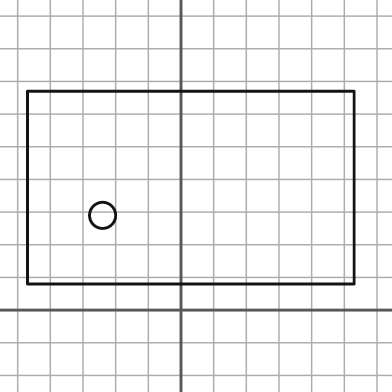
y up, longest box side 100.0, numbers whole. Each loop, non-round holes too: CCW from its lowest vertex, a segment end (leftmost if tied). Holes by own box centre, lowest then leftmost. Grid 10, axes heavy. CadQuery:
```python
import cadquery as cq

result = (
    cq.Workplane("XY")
    .moveTo(-47.0, 8.0)
    .lineTo(53.0, 8.0)
    .lineTo(53.0, 67.0)
    .lineTo(-47.0, 67.0)
    .close()
    .moveTo(-24.0, 29.0)
    .circle(4.0)
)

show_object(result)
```